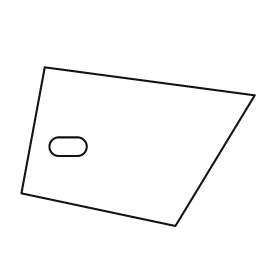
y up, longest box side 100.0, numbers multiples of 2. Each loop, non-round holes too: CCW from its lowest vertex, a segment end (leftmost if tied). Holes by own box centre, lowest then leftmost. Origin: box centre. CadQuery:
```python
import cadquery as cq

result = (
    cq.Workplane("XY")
    .moveTo(16.0, -34.0)
    .lineTo(50.0, 22.0)
    .lineTo(-40.0, 34.0)
    .lineTo(-50.0, -20.0)
    .close()
    .moveTo(-34.0, -4.0)
    .lineTo(-26.0, -4.0)
    .threePointArc((-22.0, 0.0), (-26.0, 4.0))
    .lineTo(-34.0, 4.0)
    .threePointArc((-38.0, 0.0), (-34.0, -4.0))
    .close()
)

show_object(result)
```